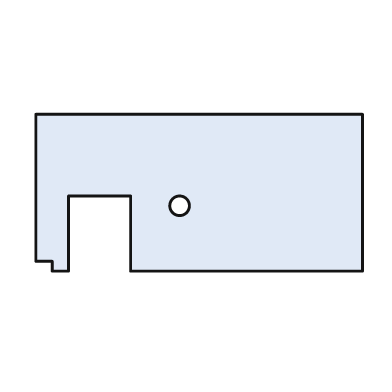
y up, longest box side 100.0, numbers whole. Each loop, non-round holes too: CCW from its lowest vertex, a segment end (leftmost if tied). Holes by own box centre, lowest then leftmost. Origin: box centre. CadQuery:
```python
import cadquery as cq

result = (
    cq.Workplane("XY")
    .moveTo(-45.0, -24.0)
    .lineTo(-40.0, -24.0)
    .lineTo(-40.0, -1.0)
    .lineTo(-21.0, -1.0)
    .lineTo(-21.0, -24.0)
    .lineTo(50.0, -24.0)
    .lineTo(50.0, 24.0)
    .lineTo(-50.0, 24.0)
    .lineTo(-50.0, -21.0)
    .lineTo(-45.0, -21.0)
    .close()
    .moveTo(-6.0, -4.0)
    .circle(3.0)
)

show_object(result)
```